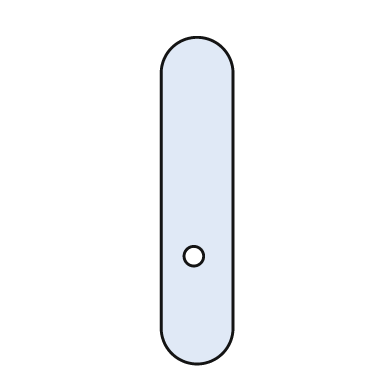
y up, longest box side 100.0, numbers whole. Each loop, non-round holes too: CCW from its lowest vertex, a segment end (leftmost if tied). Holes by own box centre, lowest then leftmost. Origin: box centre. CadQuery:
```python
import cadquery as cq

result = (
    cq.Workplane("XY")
    .moveTo(-11.0, -39.0)
    .threePointArc((0.0, -50.0), (11.0, -39.0))
    .lineTo(11.0, 39.0)
    .threePointArc((0.0, 50.0), (-11.0, 39.0))
    .close()
    .moveTo(-1.0, -17.0)
    .circle(3.0)
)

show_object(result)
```